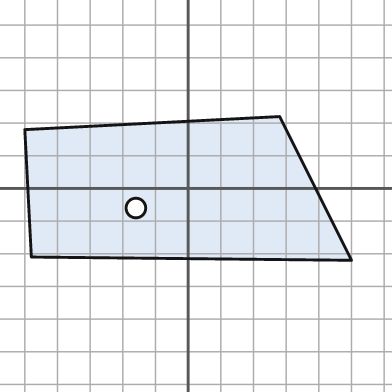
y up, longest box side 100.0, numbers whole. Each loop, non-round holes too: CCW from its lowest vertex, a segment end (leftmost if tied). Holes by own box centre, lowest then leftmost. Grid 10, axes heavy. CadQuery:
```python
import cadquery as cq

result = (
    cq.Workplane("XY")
    .moveTo(50.0, -22.0)
    .lineTo(28.0, 22.0)
    .lineTo(-50.0, 18.0)
    .lineTo(-48.0, -21.0)
    .close()
    .moveTo(-16.0, -6.0)
    .circle(3.0)
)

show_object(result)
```